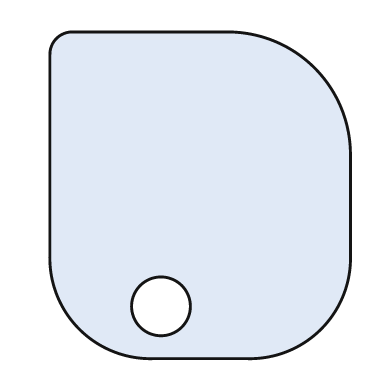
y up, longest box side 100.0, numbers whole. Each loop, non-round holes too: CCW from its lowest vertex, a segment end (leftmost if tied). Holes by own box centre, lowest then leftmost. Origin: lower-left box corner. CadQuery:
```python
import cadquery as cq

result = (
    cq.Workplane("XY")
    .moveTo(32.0, 0.0)
    .lineTo(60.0, 0.0)
    .threePointArc((83.0, 9.0), (92.0, 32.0))
    .lineTo(92.0, 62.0)
    .threePointArc((81.0, 89.0), (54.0, 100.0))
    .lineTo(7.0, 100.0)
    .threePointArc((2.0, 98.0), (0.0, 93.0))
    .lineTo(0.0, 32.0)
    .threePointArc((9.0, 9.0), (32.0, 0.0))
    .close()
    .moveTo(34.0, 16.0)
    .circle(9.0)
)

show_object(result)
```